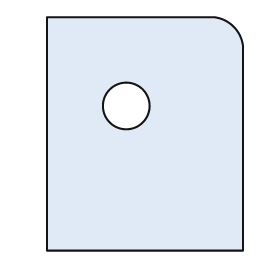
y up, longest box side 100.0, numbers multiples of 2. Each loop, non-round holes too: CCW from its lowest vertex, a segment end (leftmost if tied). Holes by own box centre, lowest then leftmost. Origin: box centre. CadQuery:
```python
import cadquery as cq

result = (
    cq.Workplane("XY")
    .moveTo(-42.0, -50.0)
    .lineTo(42.0, -50.0)
    .lineTo(42.0, 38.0)
    .threePointArc((38.0, 46.0), (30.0, 50.0))
    .lineTo(-42.0, 50.0)
    .close()
    .moveTo(-8.0, 12.0)
    .circle(10.0)
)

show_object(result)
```